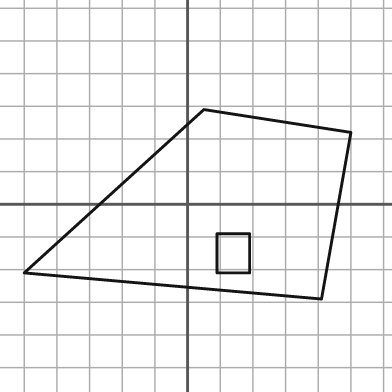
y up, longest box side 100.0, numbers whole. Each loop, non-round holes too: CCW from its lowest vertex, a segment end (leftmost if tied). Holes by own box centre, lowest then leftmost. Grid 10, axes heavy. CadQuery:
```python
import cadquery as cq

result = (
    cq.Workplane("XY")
    .moveTo(41.0, -29.0)
    .lineTo(50.0, 22.0)
    .lineTo(5.0, 29.0)
    .lineTo(-50.0, -21.0)
    .close()
    .moveTo(9.0, -21.0)
    .lineTo(19.0, -21.0)
    .lineTo(19.0, -9.0)
    .lineTo(9.0, -9.0)
    .close()
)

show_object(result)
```